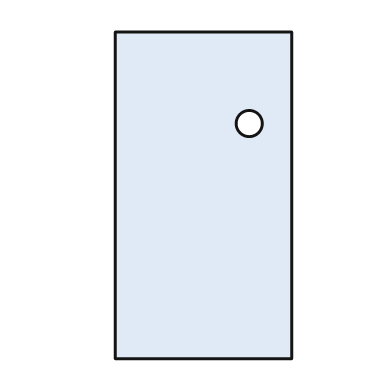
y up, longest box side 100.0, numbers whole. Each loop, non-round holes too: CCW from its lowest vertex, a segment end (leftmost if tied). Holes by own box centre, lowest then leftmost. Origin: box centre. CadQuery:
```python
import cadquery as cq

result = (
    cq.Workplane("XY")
    .moveTo(-27.0, -50.0)
    .lineTo(27.0, -50.0)
    .lineTo(27.0, 50.0)
    .lineTo(-27.0, 50.0)
    .close()
    .moveTo(14.0, 22.0)
    .circle(4.0)
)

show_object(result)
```